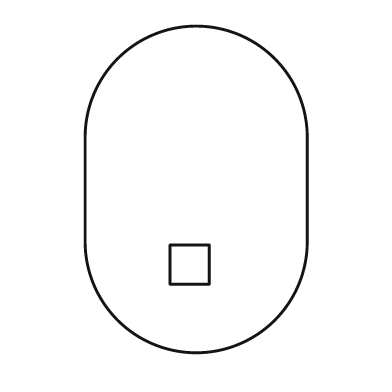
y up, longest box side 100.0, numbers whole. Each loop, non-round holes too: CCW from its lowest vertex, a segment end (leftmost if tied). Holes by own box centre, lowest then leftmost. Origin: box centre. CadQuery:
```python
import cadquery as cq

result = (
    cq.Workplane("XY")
    .moveTo(-34.0, -16.0)
    .threePointArc((0.0, -50.0), (34.0, -16.0))
    .lineTo(34.0, 16.0)
    .threePointArc((0.0, 50.0), (-34.0, 16.0))
    .close()
    .moveTo(-8.0, -29.0)
    .lineTo(4.0, -29.0)
    .lineTo(4.0, -17.0)
    .lineTo(-8.0, -17.0)
    .close()
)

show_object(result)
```